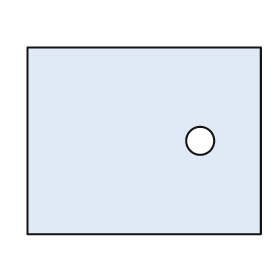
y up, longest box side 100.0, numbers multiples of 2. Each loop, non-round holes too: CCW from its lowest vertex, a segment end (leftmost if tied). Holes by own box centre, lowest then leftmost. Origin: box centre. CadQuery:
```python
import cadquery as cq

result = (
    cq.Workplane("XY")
    .moveTo(-50.0, -40.0)
    .lineTo(50.0, -40.0)
    .lineTo(50.0, 40.0)
    .lineTo(-50.0, 40.0)
    .close()
    .moveTo(24.0, 0.0)
    .circle(6.0)
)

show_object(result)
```